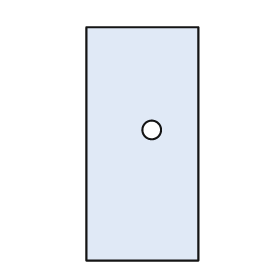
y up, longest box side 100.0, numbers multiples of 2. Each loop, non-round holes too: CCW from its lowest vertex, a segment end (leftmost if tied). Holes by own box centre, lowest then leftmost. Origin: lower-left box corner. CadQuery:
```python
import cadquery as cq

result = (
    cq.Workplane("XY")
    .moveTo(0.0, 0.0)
    .lineTo(48.0, 0.0)
    .lineTo(48.0, 100.0)
    .lineTo(0.0, 100.0)
    .close()
    .moveTo(28.0, 56.0)
    .circle(4.0)
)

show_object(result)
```